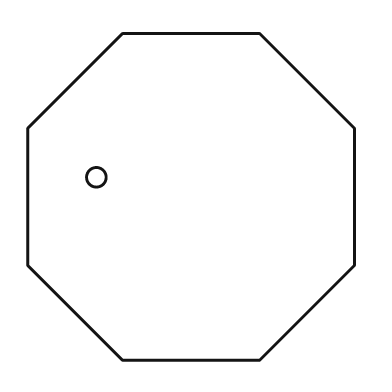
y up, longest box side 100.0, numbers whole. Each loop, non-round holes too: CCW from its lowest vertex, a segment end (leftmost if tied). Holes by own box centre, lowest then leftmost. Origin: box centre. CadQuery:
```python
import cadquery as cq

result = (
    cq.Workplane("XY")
    .moveTo(-21.0, -50.0)
    .lineTo(21.0, -50.0)
    .lineTo(50.0, -21.0)
    .lineTo(50.0, 21.0)
    .lineTo(21.0, 50.0)
    .lineTo(-21.0, 50.0)
    .lineTo(-50.0, 21.0)
    .lineTo(-50.0, -21.0)
    .close()
    .moveTo(-29.0, 6.0)
    .circle(3.0)
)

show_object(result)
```